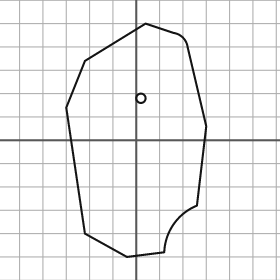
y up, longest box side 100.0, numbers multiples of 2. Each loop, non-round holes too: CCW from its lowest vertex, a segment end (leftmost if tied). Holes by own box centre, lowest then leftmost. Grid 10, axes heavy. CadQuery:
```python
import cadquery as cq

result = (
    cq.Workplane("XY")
    .moveTo(-4.0, -50.0)
    .lineTo(12.0, -48.0)
    .threePointArc((16.0, -36.0), (26.0, -28.0))
    .lineTo(30.0, 6.0)
    .lineTo(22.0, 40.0)
    .threePointArc((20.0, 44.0), (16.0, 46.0))
    .lineTo(4.0, 50.0)
    .lineTo(-22.0, 34.0)
    .lineTo(-30.0, 14.0)
    .lineTo(-22.0, -40.0)
    .close()
    .moveTo(2.0, 18.0)
    .circle(2.0)
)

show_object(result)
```